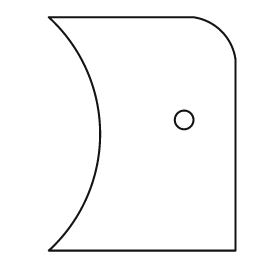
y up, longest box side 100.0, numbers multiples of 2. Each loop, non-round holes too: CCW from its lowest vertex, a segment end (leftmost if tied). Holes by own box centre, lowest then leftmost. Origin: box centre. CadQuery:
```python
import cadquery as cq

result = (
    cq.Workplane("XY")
    .moveTo(-40.0, -50.0)
    .lineTo(40.0, -50.0)
    .lineTo(40.0, 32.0)
    .threePointArc((34.0, 44.0), (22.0, 50.0))
    .lineTo(-40.0, 50.0)
    .threePointArc((-18.0, 0.0), (-40.0, -50.0))
    .close()
    .moveTo(18.0, 6.0)
    .circle(4.0)
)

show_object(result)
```